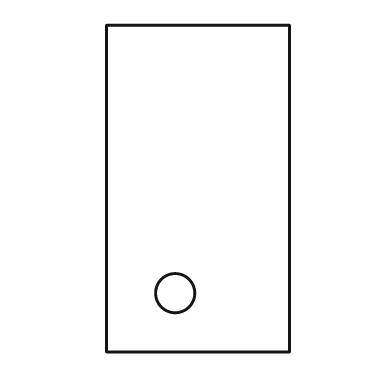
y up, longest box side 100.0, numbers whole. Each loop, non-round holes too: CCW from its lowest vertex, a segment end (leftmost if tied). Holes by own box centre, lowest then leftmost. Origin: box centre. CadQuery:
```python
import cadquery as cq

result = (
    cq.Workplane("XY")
    .moveTo(-28.0, -50.0)
    .lineTo(28.0, -50.0)
    .lineTo(28.0, 50.0)
    .lineTo(-28.0, 50.0)
    .close()
    .moveTo(-7.0, -32.0)
    .circle(6.0)
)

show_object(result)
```